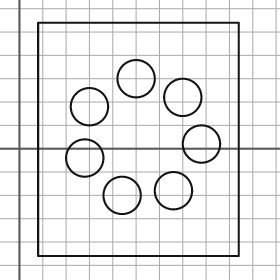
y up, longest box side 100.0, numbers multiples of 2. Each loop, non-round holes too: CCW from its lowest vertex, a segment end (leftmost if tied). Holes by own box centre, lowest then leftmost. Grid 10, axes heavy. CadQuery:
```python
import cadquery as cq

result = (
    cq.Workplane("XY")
    .moveTo(8.0, -46.0)
    .lineTo(94.0, -46.0)
    .lineTo(94.0, 54.0)
    .lineTo(8.0, 54.0)
    .close()
    .moveTo(44.0, -20.0)
    .circle(8.0)
    .moveTo(66.0, -18.0)
    .circle(8.0)
    .moveTo(28.0, -4.0)
    .circle(8.0)
    .moveTo(78.0, 2.0)
    .circle(8.0)
    .moveTo(30.0, 18.0)
    .circle(8.0)
    .moveTo(70.0, 22.0)
    .circle(8.0)
    .moveTo(50.0, 30.0)
    .circle(8.0)
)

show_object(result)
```